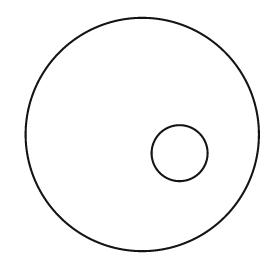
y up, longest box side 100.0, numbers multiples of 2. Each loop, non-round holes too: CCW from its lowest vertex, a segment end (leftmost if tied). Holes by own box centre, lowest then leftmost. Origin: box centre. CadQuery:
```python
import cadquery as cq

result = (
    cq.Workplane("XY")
    .moveTo(0.0, 0.0)
    .circle(50.0)
    .moveTo(16.0, -8.0)
    .circle(12.0)
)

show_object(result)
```